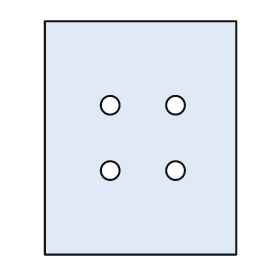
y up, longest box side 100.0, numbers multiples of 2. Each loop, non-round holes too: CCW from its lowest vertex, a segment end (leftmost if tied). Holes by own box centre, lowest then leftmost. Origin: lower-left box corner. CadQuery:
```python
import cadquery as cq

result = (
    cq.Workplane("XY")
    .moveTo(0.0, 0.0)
    .lineTo(82.0, 0.0)
    .lineTo(82.0, 100.0)
    .lineTo(0.0, 100.0)
    .close()
    .moveTo(28.0, 36.0)
    .circle(4.0)
    .moveTo(56.0, 36.0)
    .circle(4.0)
    .moveTo(28.0, 64.0)
    .circle(4.0)
    .moveTo(56.0, 64.0)
    .circle(4.0)
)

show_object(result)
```